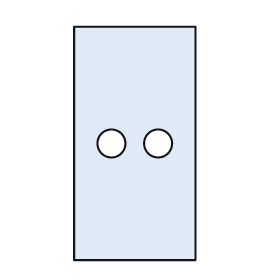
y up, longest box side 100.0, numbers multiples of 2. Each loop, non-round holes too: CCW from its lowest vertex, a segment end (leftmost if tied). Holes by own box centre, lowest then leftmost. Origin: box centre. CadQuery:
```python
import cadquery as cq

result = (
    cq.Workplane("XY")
    .moveTo(-26.0, -50.0)
    .lineTo(26.0, -50.0)
    .lineTo(26.0, 50.0)
    .lineTo(-26.0, 50.0)
    .close()
    .moveTo(-10.0, 0.0)
    .circle(6.0)
    .moveTo(10.0, 0.0)
    .circle(6.0)
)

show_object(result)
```